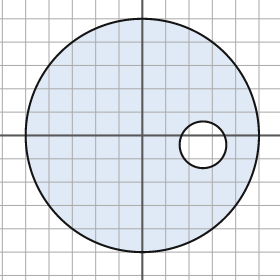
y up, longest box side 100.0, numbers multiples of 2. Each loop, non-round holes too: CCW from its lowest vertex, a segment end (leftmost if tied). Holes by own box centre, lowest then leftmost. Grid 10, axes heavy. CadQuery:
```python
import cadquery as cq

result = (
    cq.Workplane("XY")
    .moveTo(0.0, 0.0)
    .circle(50.0)
    .moveTo(26.0, -4.0)
    .circle(10.0)
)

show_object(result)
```